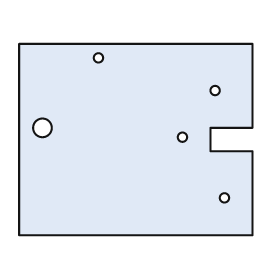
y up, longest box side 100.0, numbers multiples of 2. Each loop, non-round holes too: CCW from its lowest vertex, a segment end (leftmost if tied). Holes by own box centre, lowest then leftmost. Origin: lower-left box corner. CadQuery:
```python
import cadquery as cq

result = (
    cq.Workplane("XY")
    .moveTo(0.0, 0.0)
    .lineTo(100.0, 0.0)
    .lineTo(100.0, 36.0)
    .lineTo(82.0, 36.0)
    .lineTo(82.0, 46.0)
    .lineTo(100.0, 46.0)
    .lineTo(100.0, 82.0)
    .lineTo(0.0, 82.0)
    .close()
    .moveTo(88.0, 16.0)
    .circle(2.0)
    .moveTo(70.0, 42.0)
    .circle(2.0)
    .moveTo(10.0, 46.0)
    .circle(4.0)
    .moveTo(84.0, 62.0)
    .circle(2.0)
    .moveTo(34.0, 76.0)
    .circle(2.0)
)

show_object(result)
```